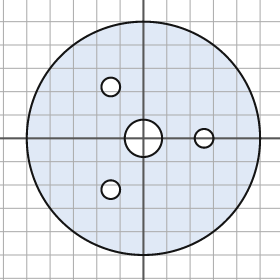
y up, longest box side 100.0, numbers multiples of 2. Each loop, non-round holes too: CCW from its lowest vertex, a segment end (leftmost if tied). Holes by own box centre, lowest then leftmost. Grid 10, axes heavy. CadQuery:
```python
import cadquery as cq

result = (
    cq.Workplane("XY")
    .moveTo(0.0, 0.0)
    .circle(50.0)
    .moveTo(-14.0, -22.0)
    .circle(4.0)
    .moveTo(0.0, 0.0)
    .circle(8.0)
    .moveTo(26.0, 0.0)
    .circle(4.0)
    .moveTo(-14.0, 22.0)
    .circle(4.0)
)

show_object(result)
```